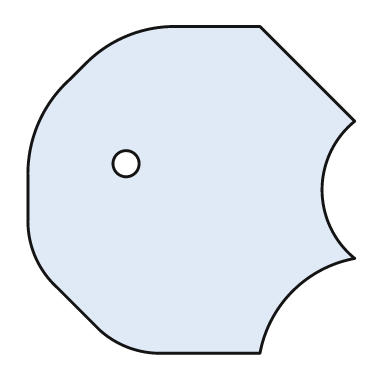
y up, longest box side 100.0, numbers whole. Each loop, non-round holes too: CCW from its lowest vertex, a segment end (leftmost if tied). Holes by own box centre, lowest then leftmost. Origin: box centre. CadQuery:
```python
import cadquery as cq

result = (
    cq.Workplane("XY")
    .moveTo(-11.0, -50.0)
    .lineTo(21.0, -50.0)
    .threePointArc((31.0, -31.0), (50.0, -21.0))
    .threePointArc((40.0, 0.0), (50.0, 21.0))
    .lineTo(21.0, 50.0)
    .lineTo(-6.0, 50.0)
    .threePointArc((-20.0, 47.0), (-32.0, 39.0))
    .lineTo(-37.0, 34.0)
    .threePointArc((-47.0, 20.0), (-50.0, 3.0))
    .lineTo(-50.0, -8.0)
    .threePointArc((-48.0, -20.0), (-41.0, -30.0))
    .lineTo(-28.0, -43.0)
    .threePointArc((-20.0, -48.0), (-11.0, -50.0))
    .close()
    .moveTo(-20.0, 8.0)
    .circle(4.0)
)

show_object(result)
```